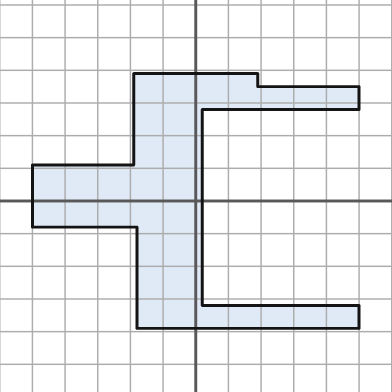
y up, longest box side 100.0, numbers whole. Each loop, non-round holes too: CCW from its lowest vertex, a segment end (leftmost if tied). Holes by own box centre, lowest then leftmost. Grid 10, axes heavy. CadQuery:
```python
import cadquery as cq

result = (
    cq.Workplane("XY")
    .moveTo(-18.0, -39.0)
    .lineTo(50.0, -39.0)
    .lineTo(50.0, -32.0)
    .lineTo(2.0, -32.0)
    .lineTo(2.0, 28.0)
    .lineTo(50.0, 28.0)
    .lineTo(50.0, 35.0)
    .lineTo(19.0, 35.0)
    .lineTo(19.0, 39.0)
    .lineTo(-19.0, 39.0)
    .lineTo(-19.0, 11.0)
    .lineTo(-50.0, 11.0)
    .lineTo(-50.0, -8.0)
    .lineTo(-18.0, -8.0)
    .close()
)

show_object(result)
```